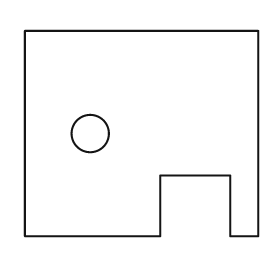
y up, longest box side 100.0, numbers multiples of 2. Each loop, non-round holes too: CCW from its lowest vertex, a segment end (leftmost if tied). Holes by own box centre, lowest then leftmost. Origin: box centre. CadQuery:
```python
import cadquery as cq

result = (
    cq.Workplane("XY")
    .moveTo(-50.0, -44.0)
    .lineTo(8.0, -44.0)
    .lineTo(8.0, -18.0)
    .lineTo(38.0, -18.0)
    .lineTo(38.0, -44.0)
    .lineTo(50.0, -44.0)
    .lineTo(50.0, 44.0)
    .lineTo(-50.0, 44.0)
    .close()
    .moveTo(-22.0, 0.0)
    .circle(8.0)
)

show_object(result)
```